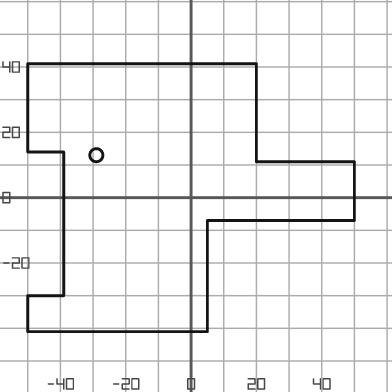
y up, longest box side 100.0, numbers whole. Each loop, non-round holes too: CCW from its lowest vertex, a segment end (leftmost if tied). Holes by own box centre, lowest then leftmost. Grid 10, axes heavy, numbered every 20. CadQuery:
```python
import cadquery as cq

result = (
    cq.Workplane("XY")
    .moveTo(-50.0, -41.0)
    .lineTo(5.0, -41.0)
    .lineTo(5.0, -7.0)
    .lineTo(50.0, -7.0)
    .lineTo(50.0, 11.0)
    .lineTo(20.0, 11.0)
    .lineTo(20.0, 41.0)
    .lineTo(-50.0, 41.0)
    .lineTo(-50.0, 14.0)
    .lineTo(-39.0, 14.0)
    .lineTo(-39.0, -30.0)
    .lineTo(-50.0, -30.0)
    .close()
    .moveTo(-29.0, 13.0)
    .circle(2.0)
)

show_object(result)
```